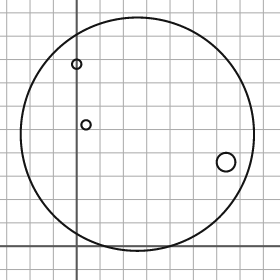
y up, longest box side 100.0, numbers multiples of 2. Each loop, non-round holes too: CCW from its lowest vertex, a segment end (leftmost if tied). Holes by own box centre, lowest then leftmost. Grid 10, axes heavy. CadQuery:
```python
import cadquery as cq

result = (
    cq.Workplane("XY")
    .moveTo(26.0, 48.0)
    .circle(50.0)
    .moveTo(64.0, 36.0)
    .circle(4.0)
    .moveTo(4.0, 52.0)
    .circle(2.0)
    .moveTo(0.0, 78.0)
    .circle(2.0)
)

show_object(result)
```